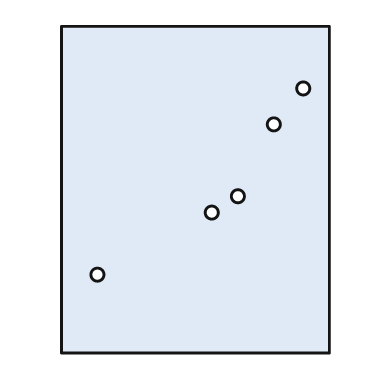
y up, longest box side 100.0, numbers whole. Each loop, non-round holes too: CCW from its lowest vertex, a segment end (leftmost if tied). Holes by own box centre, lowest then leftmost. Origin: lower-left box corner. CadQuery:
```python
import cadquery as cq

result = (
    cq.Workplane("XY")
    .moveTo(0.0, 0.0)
    .lineTo(82.0, 0.0)
    .lineTo(82.0, 100.0)
    .lineTo(0.0, 100.0)
    .close()
    .moveTo(11.0, 24.0)
    .circle(2.0)
    .moveTo(46.0, 43.0)
    .circle(2.0)
    .moveTo(54.0, 48.0)
    .circle(2.0)
    .moveTo(65.0, 70.0)
    .circle(2.0)
    .moveTo(74.0, 81.0)
    .circle(2.0)
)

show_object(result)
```